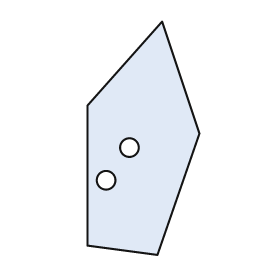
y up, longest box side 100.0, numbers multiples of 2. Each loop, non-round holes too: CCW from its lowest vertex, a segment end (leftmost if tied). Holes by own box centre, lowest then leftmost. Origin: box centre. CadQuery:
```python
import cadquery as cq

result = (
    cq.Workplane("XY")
    .moveTo(6.0, -50.0)
    .lineTo(24.0, 2.0)
    .lineTo(8.0, 50.0)
    .lineTo(-24.0, 14.0)
    .lineTo(-24.0, -46.0)
    .close()
    .moveTo(-16.0, -18.0)
    .circle(4.0)
    .moveTo(-6.0, -4.0)
    .circle(4.0)
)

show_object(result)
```